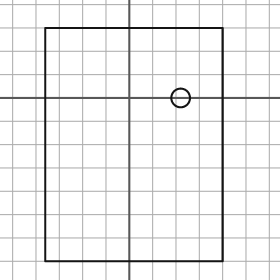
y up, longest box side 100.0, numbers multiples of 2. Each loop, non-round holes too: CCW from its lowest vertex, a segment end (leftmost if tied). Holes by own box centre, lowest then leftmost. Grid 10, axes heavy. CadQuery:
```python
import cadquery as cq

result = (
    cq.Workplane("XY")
    .moveTo(-36.0, -70.0)
    .lineTo(40.0, -70.0)
    .lineTo(40.0, 30.0)
    .lineTo(-36.0, 30.0)
    .close()
    .moveTo(22.0, 0.0)
    .circle(4.0)
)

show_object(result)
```